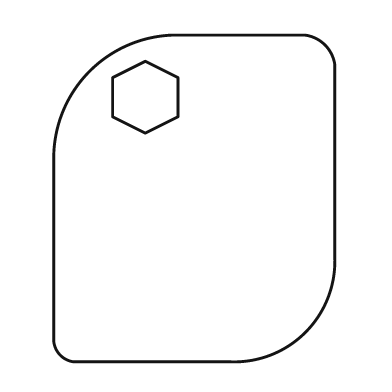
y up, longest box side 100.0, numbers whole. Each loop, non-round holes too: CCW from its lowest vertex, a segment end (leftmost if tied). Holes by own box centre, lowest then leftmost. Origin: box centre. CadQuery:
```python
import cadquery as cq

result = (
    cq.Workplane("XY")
    .moveTo(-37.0, -50.0)
    .lineTo(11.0, -50.0)
    .threePointArc((34.0, -41.0), (43.0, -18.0))
    .lineTo(43.0, 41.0)
    .threePointArc((40.0, 47.0), (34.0, 50.0))
    .lineTo(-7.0, 50.0)
    .threePointArc((-32.0, 39.0), (-43.0, 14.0))
    .lineTo(-43.0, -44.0)
    .threePointArc((-41.0, -48.0), (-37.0, -50.0))
    .close()
    .moveTo(-15.0, 20.0)
    .lineTo(-5.0, 25.0)
    .lineTo(-5.0, 37.0)
    .lineTo(-15.0, 42.0)
    .lineTo(-25.0, 37.0)
    .lineTo(-25.0, 25.0)
    .close()
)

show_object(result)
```